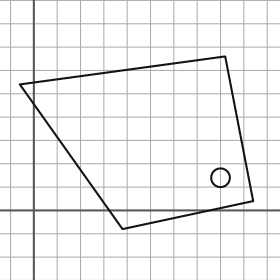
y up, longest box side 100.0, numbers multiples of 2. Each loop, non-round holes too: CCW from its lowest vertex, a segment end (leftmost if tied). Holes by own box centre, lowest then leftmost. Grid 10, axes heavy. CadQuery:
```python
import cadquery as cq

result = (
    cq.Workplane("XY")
    .moveTo(38.0, -8.0)
    .lineTo(94.0, 4.0)
    .lineTo(82.0, 66.0)
    .lineTo(-6.0, 54.0)
    .close()
    .moveTo(80.0, 14.0)
    .circle(4.0)
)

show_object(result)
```